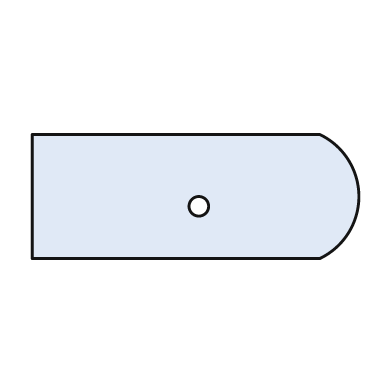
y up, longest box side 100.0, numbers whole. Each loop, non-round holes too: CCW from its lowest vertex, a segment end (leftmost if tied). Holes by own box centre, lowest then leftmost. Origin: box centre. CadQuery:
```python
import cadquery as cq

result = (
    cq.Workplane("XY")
    .moveTo(-50.0, -19.0)
    .lineTo(38.0, -19.0)
    .threePointArc((50.0, 0.0), (38.0, 19.0))
    .lineTo(-50.0, 19.0)
    .close()
    .moveTo(1.0, -3.0)
    .circle(3.0)
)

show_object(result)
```